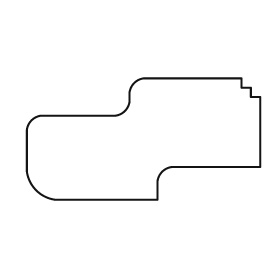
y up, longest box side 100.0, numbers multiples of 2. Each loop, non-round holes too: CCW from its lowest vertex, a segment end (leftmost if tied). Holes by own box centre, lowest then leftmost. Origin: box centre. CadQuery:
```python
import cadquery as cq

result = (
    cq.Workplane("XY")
    .moveTo(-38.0, -26.0)
    .lineTo(6.0, -26.0)
    .lineTo(6.0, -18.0)
    .threePointArc((8.0, -14.0), (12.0, -12.0))
    .lineTo(50.0, -12.0)
    .lineTo(50.0, 18.0)
    .lineTo(46.0, 18.0)
    .lineTo(46.0, 22.0)
    .lineTo(42.0, 22.0)
    .lineTo(42.0, 26.0)
    .lineTo(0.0, 26.0)
    .threePointArc((-4.0, 24.0), (-6.0, 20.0))
    .lineTo(-6.0, 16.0)
    .threePointArc((-8.0, 12.0), (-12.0, 10.0))
    .lineTo(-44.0, 10.0)
    .threePointArc((-48.0, 8.0), (-50.0, 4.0))
    .lineTo(-50.0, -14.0)
    .threePointArc((-46.0, -22.0), (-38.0, -26.0))
    .close()
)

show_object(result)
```